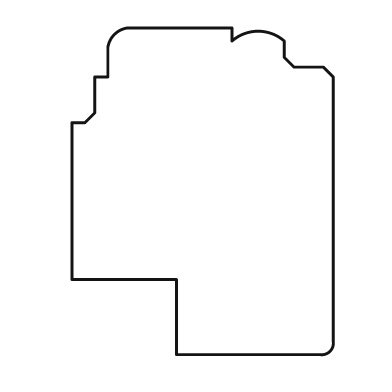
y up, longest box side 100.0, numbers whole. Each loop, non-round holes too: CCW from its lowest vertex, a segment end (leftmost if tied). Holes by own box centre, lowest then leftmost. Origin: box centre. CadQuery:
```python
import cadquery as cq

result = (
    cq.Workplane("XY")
    .moveTo(-8.0, -50.0)
    .lineTo(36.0, -50.0)
    .threePointArc((39.0, -49.0), (40.0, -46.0))
    .lineTo(40.0, 35.0)
    .lineTo(37.0, 38.0)
    .lineTo(28.0, 38.0)
    .lineTo(25.0, 41.0)
    .lineTo(25.0, 46.0)
    .threePointArc((17.0, 49.0), (9.0, 46.0))
    .lineTo(9.0, 50.0)
    .lineTo(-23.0, 50.0)
    .threePointArc((-27.0, 48.0), (-29.0, 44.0))
    .lineTo(-29.0, 35.0)
    .lineTo(-33.0, 35.0)
    .lineTo(-33.0, 24.0)
    .lineTo(-36.0, 21.0)
    .lineTo(-40.0, 21.0)
    .lineTo(-40.0, -27.0)
    .lineTo(-8.0, -27.0)
    .close()
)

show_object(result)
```